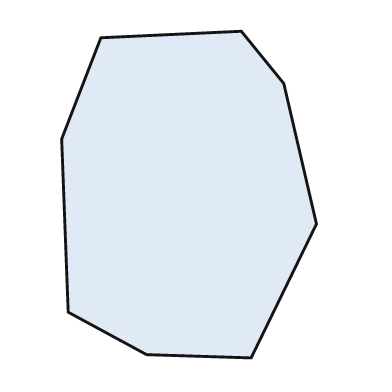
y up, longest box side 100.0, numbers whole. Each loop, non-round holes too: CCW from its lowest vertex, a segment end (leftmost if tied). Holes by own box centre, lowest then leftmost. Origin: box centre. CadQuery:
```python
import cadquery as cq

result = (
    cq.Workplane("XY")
    .moveTo(19.0, -50.0)
    .lineTo(39.0, -9.0)
    .lineTo(29.0, 34.0)
    .lineTo(16.0, 50.0)
    .lineTo(-27.0, 48.0)
    .lineTo(-39.0, 17.0)
    .lineTo(-37.0, -36.0)
    .lineTo(-13.0, -49.0)
    .close()
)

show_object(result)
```